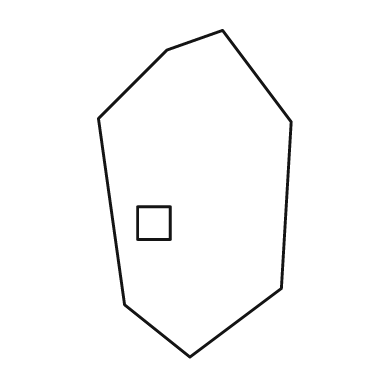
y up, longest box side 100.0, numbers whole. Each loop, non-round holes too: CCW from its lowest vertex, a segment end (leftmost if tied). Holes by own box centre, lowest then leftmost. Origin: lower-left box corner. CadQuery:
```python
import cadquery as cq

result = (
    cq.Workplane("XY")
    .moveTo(28.0, 0.0)
    .lineTo(56.0, 21.0)
    .lineTo(59.0, 72.0)
    .lineTo(38.0, 100.0)
    .lineTo(21.0, 94.0)
    .lineTo(0.0, 73.0)
    .lineTo(8.0, 16.0)
    .close()
    .moveTo(12.0, 36.0)
    .lineTo(22.0, 36.0)
    .lineTo(22.0, 46.0)
    .lineTo(12.0, 46.0)
    .close()
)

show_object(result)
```